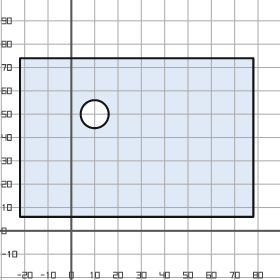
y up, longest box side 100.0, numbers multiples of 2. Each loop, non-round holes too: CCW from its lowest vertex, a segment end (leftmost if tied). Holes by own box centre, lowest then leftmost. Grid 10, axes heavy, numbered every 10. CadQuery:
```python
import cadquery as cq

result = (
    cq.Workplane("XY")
    .moveTo(-22.0, 6.0)
    .lineTo(78.0, 6.0)
    .lineTo(78.0, 74.0)
    .lineTo(-22.0, 74.0)
    .close()
    .moveTo(10.0, 50.0)
    .circle(6.0)
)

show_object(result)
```